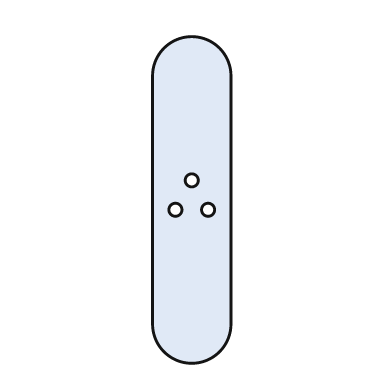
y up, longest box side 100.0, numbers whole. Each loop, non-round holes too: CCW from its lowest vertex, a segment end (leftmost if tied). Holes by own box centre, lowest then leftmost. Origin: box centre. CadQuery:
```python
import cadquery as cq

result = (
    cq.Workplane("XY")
    .moveTo(-12.0, -38.0)
    .threePointArc((0.0, -50.0), (12.0, -38.0))
    .lineTo(12.0, 38.0)
    .threePointArc((0.0, 50.0), (-12.0, 38.0))
    .close()
    .moveTo(-5.0, -3.0)
    .circle(2.0)
    .moveTo(5.0, -3.0)
    .circle(2.0)
    .moveTo(0.0, 6.0)
    .circle(2.0)
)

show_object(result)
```